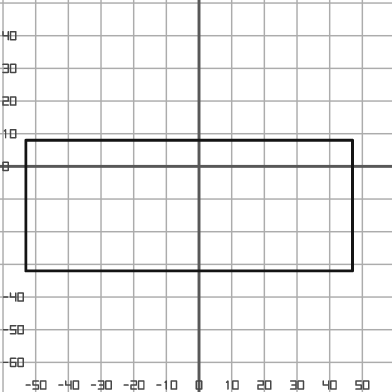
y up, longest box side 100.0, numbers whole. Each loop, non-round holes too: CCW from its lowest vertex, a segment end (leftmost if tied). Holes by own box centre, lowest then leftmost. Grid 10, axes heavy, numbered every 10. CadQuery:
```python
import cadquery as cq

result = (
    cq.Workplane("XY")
    .moveTo(-53.0, -32.0)
    .lineTo(47.0, -32.0)
    .lineTo(47.0, 8.0)
    .lineTo(-53.0, 8.0)
    .close()
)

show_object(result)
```